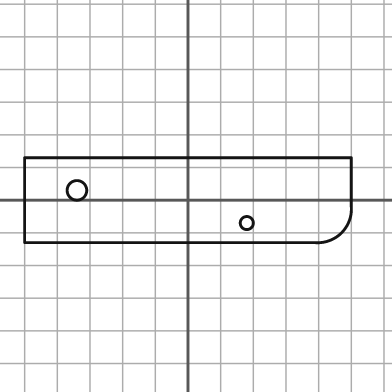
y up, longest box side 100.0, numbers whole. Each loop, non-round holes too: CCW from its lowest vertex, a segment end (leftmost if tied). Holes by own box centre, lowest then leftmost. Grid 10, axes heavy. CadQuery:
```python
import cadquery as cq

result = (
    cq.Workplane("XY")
    .moveTo(-50.0, -13.0)
    .lineTo(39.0, -13.0)
    .threePointArc((47.0, -10.0), (50.0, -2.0))
    .lineTo(50.0, 13.0)
    .lineTo(-50.0, 13.0)
    .close()
    .moveTo(18.0, -7.0)
    .circle(2.0)
    .moveTo(-34.0, 3.0)
    .circle(3.0)
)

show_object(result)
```